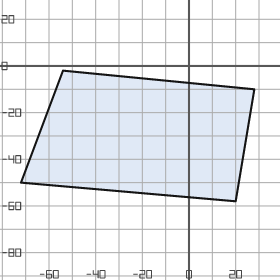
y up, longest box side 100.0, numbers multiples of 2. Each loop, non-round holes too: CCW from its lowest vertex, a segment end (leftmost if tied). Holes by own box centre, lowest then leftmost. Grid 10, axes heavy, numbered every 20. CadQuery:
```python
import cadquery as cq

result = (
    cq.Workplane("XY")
    .moveTo(20.0, -58.0)
    .lineTo(28.0, -10.0)
    .lineTo(-54.0, -2.0)
    .lineTo(-72.0, -50.0)
    .close()
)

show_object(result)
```